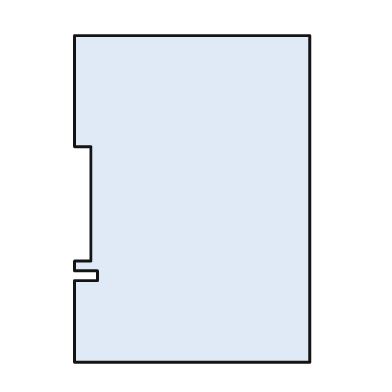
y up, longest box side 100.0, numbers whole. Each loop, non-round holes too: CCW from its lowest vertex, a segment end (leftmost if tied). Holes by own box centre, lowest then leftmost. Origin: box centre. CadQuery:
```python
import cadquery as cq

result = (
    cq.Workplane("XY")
    .moveTo(-36.0, -50.0)
    .lineTo(36.0, -50.0)
    .lineTo(36.0, 50.0)
    .lineTo(-36.0, 50.0)
    .lineTo(-36.0, 16.0)
    .lineTo(-31.0, 16.0)
    .lineTo(-31.0, -19.0)
    .lineTo(-36.0, -19.0)
    .lineTo(-36.0, -22.0)
    .lineTo(-29.0, -22.0)
    .lineTo(-29.0, -25.0)
    .lineTo(-36.0, -25.0)
    .close()
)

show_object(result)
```